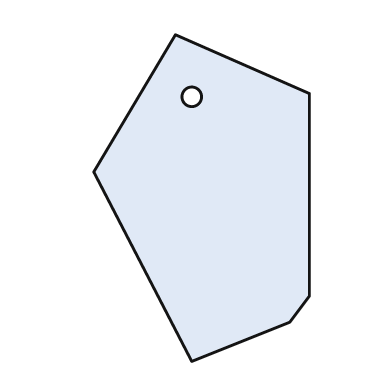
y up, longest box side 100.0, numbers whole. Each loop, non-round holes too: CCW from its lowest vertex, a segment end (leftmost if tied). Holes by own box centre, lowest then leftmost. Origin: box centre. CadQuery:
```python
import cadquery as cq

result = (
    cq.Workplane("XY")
    .moveTo(-3.0, -50.0)
    .lineTo(27.0, -38.0)
    .lineTo(33.0, -30.0)
    .lineTo(33.0, 32.0)
    .lineTo(-8.0, 50.0)
    .lineTo(-33.0, 8.0)
    .close()
    .moveTo(-3.0, 31.0)
    .circle(3.0)
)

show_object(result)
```